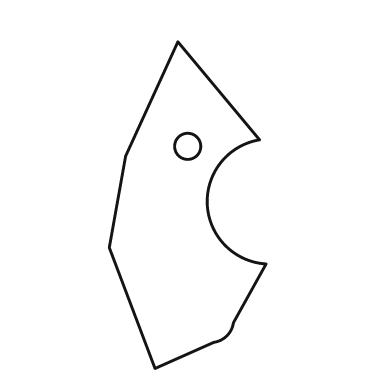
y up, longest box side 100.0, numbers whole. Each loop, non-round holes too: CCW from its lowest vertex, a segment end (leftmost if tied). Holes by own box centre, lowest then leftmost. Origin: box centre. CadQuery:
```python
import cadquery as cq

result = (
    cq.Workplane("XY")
    .moveTo(-10.0, -50.0)
    .lineTo(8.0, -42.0)
    .threePointArc((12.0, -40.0), (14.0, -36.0))
    .lineTo(24.0, -18.0)
    .threePointArc((6.0, 0.0), (22.0, 20.0))
    .lineTo(-3.0, 50.0)
    .lineTo(-19.0, 15.0)
    .lineTo(-24.0, -13.0)
    .close()
    .moveTo(0.0, 18.0)
    .circle(4.0)
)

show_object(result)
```